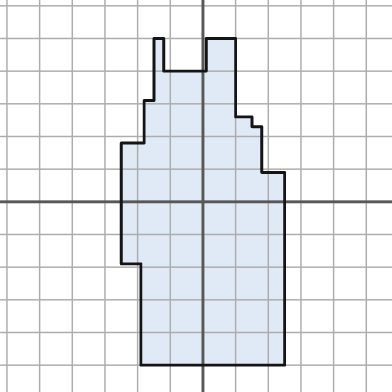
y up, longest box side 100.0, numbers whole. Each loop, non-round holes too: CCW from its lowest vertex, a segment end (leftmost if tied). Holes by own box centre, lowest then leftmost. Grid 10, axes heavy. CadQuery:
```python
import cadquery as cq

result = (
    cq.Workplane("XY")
    .moveTo(-19.0, -50.0)
    .lineTo(25.0, -50.0)
    .lineTo(25.0, 9.0)
    .lineTo(18.0, 9.0)
    .lineTo(18.0, 23.0)
    .lineTo(15.0, 23.0)
    .lineTo(15.0, 26.0)
    .lineTo(10.0, 26.0)
    .lineTo(10.0, 50.0)
    .lineTo(1.0, 50.0)
    .lineTo(1.0, 40.0)
    .lineTo(-12.0, 40.0)
    .lineTo(-12.0, 50.0)
    .lineTo(-15.0, 50.0)
    .lineTo(-15.0, 31.0)
    .lineTo(-18.0, 31.0)
    .lineTo(-18.0, 18.0)
    .lineTo(-25.0, 18.0)
    .lineTo(-25.0, -19.0)
    .lineTo(-19.0, -19.0)
    .close()
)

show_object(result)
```